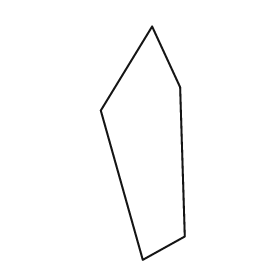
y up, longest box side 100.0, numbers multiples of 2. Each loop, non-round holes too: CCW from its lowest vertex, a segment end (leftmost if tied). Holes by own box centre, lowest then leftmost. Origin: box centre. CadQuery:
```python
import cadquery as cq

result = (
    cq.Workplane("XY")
    .moveTo(0.0, -50.0)
    .lineTo(18.0, -40.0)
    .lineTo(16.0, 24.0)
    .lineTo(4.0, 50.0)
    .lineTo(-18.0, 14.0)
    .close()
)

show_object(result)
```